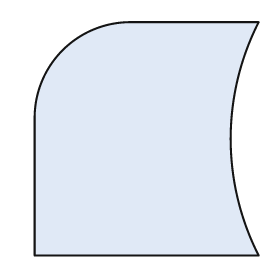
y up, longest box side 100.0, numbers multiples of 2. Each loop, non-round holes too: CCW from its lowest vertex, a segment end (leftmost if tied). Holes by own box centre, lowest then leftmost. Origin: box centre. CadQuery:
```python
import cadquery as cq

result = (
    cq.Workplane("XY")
    .moveTo(-48.0, -50.0)
    .lineTo(48.0, -50.0)
    .threePointArc((36.0, 0.0), (48.0, 50.0))
    .lineTo(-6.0, 50.0)
    .threePointArc((-36.0, 38.0), (-48.0, 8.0))
    .close()
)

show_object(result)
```